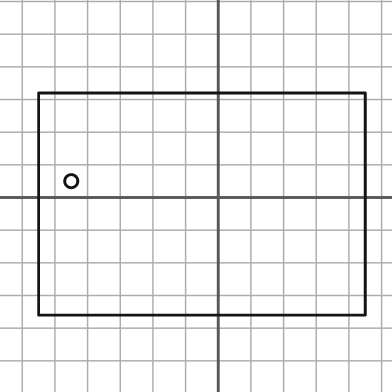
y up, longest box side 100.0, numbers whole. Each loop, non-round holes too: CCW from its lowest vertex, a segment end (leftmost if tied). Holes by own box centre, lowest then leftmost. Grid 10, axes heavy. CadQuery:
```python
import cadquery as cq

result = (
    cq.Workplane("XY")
    .moveTo(-55.0, -36.0)
    .lineTo(45.0, -36.0)
    .lineTo(45.0, 32.0)
    .lineTo(-55.0, 32.0)
    .close()
    .moveTo(-45.0, 5.0)
    .circle(2.0)
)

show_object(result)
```